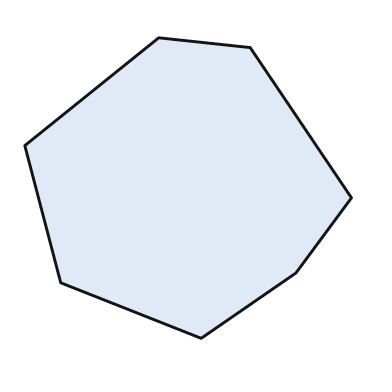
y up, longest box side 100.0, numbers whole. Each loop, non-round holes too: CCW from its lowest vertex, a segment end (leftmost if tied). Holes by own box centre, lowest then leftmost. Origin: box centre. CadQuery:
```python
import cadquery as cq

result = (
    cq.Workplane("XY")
    .moveTo(4.0, -46.0)
    .lineTo(33.0, -26.0)
    .lineTo(50.0, -3.0)
    .lineTo(19.0, 43.0)
    .lineTo(-9.0, 46.0)
    .lineTo(-50.0, 13.0)
    .lineTo(-39.0, -29.0)
    .close()
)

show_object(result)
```